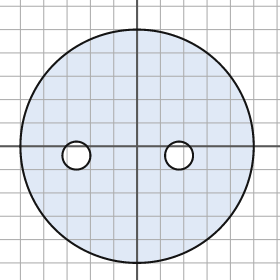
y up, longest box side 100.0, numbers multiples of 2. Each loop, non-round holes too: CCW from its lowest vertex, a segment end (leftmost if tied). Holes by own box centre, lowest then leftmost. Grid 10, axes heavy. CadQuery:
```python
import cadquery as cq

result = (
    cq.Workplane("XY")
    .moveTo(0.0, 0.0)
    .circle(50.0)
    .moveTo(-26.0, -4.0)
    .circle(6.0)
    .moveTo(18.0, -4.0)
    .circle(6.0)
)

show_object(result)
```